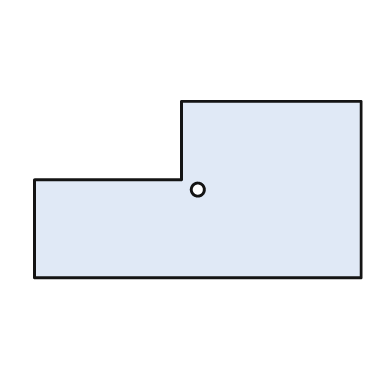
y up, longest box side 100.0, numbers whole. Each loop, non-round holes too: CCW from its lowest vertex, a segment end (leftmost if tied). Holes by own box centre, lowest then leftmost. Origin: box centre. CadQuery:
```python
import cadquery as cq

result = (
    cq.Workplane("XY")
    .moveTo(-50.0, -27.0)
    .lineTo(50.0, -27.0)
    .lineTo(50.0, 27.0)
    .lineTo(-5.0, 27.0)
    .lineTo(-5.0, 3.0)
    .lineTo(-50.0, 3.0)
    .close()
    .moveTo(0.0, 0.0)
    .circle(2.0)
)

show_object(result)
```